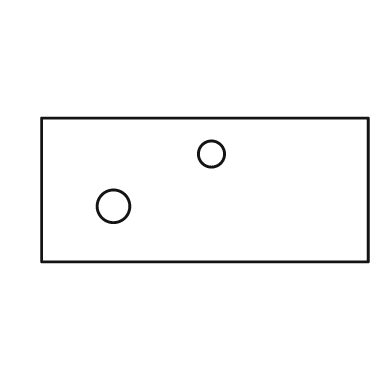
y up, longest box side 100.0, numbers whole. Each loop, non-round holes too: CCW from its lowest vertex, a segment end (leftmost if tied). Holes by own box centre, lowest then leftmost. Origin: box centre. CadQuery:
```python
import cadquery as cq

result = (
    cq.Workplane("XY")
    .moveTo(-50.0, -22.0)
    .lineTo(50.0, -22.0)
    .lineTo(50.0, 22.0)
    .lineTo(-50.0, 22.0)
    .close()
    .moveTo(-28.0, -5.0)
    .circle(5.0)
    .moveTo(2.0, 11.0)
    .circle(4.0)
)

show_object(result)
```